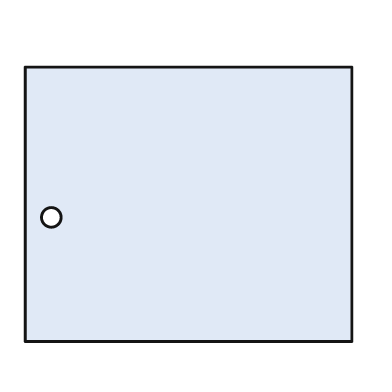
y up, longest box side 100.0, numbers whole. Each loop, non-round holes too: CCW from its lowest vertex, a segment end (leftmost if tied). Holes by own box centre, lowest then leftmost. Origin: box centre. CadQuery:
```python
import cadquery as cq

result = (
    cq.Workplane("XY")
    .moveTo(-50.0, -42.0)
    .lineTo(50.0, -42.0)
    .lineTo(50.0, 42.0)
    .lineTo(-50.0, 42.0)
    .close()
    .moveTo(-42.0, -4.0)
    .circle(3.0)
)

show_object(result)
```